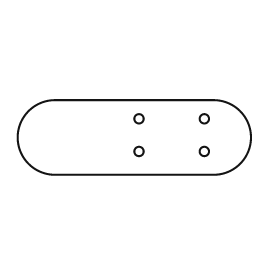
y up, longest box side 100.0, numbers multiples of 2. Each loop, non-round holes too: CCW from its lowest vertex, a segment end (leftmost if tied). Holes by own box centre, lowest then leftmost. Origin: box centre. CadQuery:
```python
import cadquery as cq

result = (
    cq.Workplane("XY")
    .moveTo(-34.0, -16.0)
    .lineTo(34.0, -16.0)
    .threePointArc((50.0, 0.0), (34.0, 16.0))
    .lineTo(-34.0, 16.0)
    .threePointArc((-50.0, 0.0), (-34.0, -16.0))
    .close()
    .moveTo(2.0, -6.0)
    .circle(2.0)
    .moveTo(30.0, -6.0)
    .circle(2.0)
    .moveTo(2.0, 8.0)
    .circle(2.0)
    .moveTo(30.0, 8.0)
    .circle(2.0)
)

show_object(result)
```